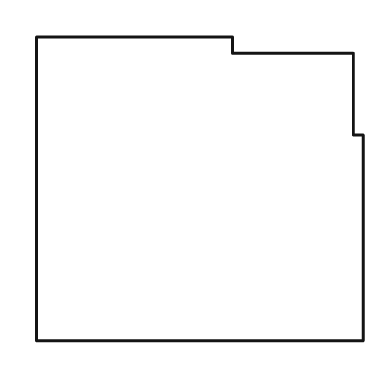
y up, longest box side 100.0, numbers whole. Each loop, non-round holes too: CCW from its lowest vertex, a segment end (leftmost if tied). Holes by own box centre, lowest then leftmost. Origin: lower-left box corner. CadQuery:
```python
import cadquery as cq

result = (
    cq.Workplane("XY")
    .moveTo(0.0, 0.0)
    .lineTo(100.0, 0.0)
    .lineTo(100.0, 63.0)
    .lineTo(97.0, 63.0)
    .lineTo(97.0, 88.0)
    .lineTo(60.0, 88.0)
    .lineTo(60.0, 93.0)
    .lineTo(0.0, 93.0)
    .close()
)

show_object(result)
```